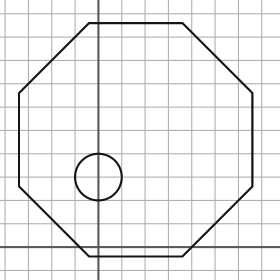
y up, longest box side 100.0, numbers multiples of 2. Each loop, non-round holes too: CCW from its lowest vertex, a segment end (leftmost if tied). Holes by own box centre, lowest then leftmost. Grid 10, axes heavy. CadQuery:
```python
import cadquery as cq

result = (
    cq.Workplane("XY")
    .moveTo(-4.0, -4.0)
    .lineTo(36.0, -4.0)
    .lineTo(66.0, 26.0)
    .lineTo(66.0, 66.0)
    .lineTo(36.0, 96.0)
    .lineTo(-4.0, 96.0)
    .lineTo(-34.0, 66.0)
    .lineTo(-34.0, 26.0)
    .close()
    .moveTo(0.0, 30.0)
    .circle(10.0)
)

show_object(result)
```